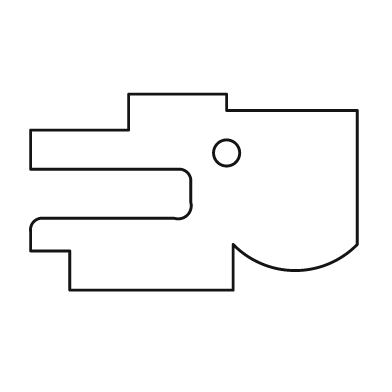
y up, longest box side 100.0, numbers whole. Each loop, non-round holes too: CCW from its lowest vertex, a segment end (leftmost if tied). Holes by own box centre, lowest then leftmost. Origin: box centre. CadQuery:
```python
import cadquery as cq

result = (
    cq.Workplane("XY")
    .moveTo(-38.0, -30.0)
    .lineTo(12.0, -30.0)
    .lineTo(12.0, -16.0)
    .threePointArc((31.0, -24.0), (50.0, -16.0))
    .lineTo(50.0, 25.0)
    .lineTo(10.0, 25.0)
    .lineTo(10.0, 30.0)
    .lineTo(-20.0, 30.0)
    .lineTo(-20.0, 19.0)
    .lineTo(-50.0, 19.0)
    .lineTo(-50.0, 7.0)
    .lineTo(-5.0, 7.0)
    .threePointArc((-2.0, 6.0), (-1.0, 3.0))
    .lineTo(-1.0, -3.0)
    .threePointArc((-2.0, -7.0), (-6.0, -8.0))
    .lineTo(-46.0, -8.0)
    .threePointArc((-49.0, -9.0), (-50.0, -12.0))
    .lineTo(-50.0, -18.0)
    .lineTo(-38.0, -18.0)
    .close()
    .moveTo(10.0, 12.0)
    .circle(4.0)
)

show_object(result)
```